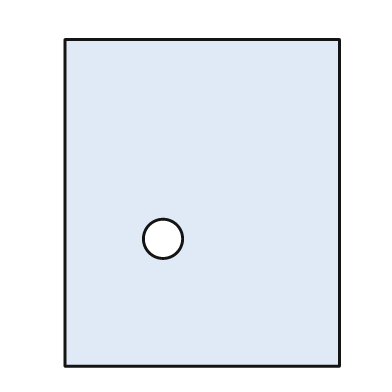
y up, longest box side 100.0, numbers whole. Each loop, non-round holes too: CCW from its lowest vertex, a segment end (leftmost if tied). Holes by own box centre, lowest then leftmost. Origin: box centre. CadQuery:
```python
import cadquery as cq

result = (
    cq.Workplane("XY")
    .moveTo(-42.0, -50.0)
    .lineTo(42.0, -50.0)
    .lineTo(42.0, 50.0)
    .lineTo(-42.0, 50.0)
    .close()
    .moveTo(-12.0, -11.0)
    .circle(6.0)
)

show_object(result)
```